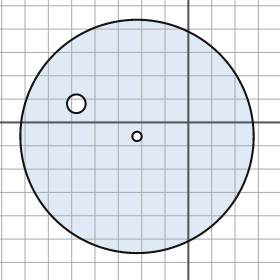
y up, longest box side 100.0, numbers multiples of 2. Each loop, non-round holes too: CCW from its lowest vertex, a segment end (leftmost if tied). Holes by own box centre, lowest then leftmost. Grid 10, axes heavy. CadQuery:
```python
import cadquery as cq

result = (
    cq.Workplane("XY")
    .moveTo(-22.0, -6.0)
    .circle(50.0)
    .moveTo(-22.0, -6.0)
    .circle(2.0)
    .moveTo(-48.0, 8.0)
    .circle(4.0)
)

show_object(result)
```